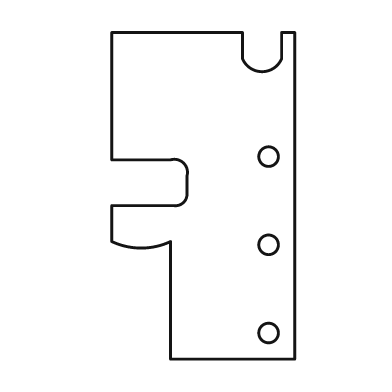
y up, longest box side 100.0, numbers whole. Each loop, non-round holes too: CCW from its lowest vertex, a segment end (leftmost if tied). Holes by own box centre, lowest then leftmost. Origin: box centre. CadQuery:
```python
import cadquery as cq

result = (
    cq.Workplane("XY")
    .moveTo(-10.0, -50.0)
    .lineTo(28.0, -50.0)
    .lineTo(28.0, 50.0)
    .lineTo(24.0, 50.0)
    .lineTo(24.0, 42.0)
    .threePointArc((18.0, 38.0), (12.0, 42.0))
    .lineTo(12.0, 50.0)
    .lineTo(-28.0, 50.0)
    .lineTo(-28.0, 11.0)
    .lineTo(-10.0, 11.0)
    .threePointArc((-6.0, 10.0), (-5.0, 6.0))
    .lineTo(-5.0, 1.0)
    .threePointArc((-6.0, -2.0), (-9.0, -3.0))
    .lineTo(-28.0, -3.0)
    .lineTo(-28.0, -14.0)
    .threePointArc((-19.0, -16.0), (-10.0, -14.0))
    .close()
    .moveTo(20.0, -42.0)
    .circle(3.0)
    .moveTo(20.0, -15.0)
    .circle(3.0)
    .moveTo(20.0, 12.0)
    .circle(3.0)
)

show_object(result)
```